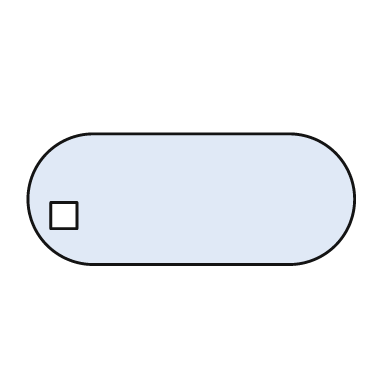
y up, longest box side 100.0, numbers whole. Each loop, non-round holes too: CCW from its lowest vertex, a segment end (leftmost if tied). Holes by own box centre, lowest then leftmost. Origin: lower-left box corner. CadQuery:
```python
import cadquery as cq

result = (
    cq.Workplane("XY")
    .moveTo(20.0, 0.0)
    .lineTo(80.0, 0.0)
    .threePointArc((100.0, 20.0), (80.0, 40.0))
    .lineTo(20.0, 40.0)
    .threePointArc((0.0, 20.0), (20.0, 0.0))
    .close()
    .moveTo(7.0, 11.0)
    .lineTo(15.0, 11.0)
    .lineTo(15.0, 19.0)
    .lineTo(7.0, 19.0)
    .close()
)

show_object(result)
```